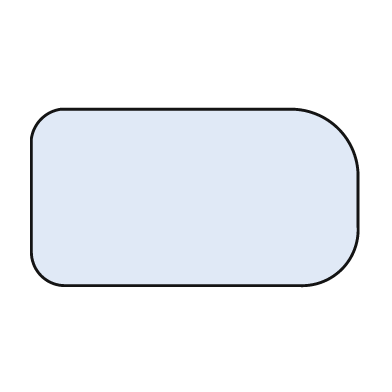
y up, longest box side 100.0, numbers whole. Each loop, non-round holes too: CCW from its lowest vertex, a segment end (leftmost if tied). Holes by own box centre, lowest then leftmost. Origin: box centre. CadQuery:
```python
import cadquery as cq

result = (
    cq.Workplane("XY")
    .moveTo(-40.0, -27.0)
    .lineTo(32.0, -27.0)
    .threePointArc((45.0, -22.0), (50.0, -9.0))
    .lineTo(50.0, 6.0)
    .threePointArc((44.0, 21.0), (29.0, 27.0))
    .lineTo(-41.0, 27.0)
    .threePointArc((-47.0, 24.0), (-50.0, 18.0))
    .lineTo(-50.0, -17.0)
    .threePointArc((-47.0, -24.0), (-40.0, -27.0))
    .close()
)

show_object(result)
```